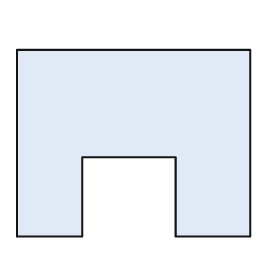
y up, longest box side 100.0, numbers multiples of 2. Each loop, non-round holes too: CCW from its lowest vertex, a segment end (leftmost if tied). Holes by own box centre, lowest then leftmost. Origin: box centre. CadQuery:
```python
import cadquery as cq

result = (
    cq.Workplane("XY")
    .moveTo(-50.0, -40.0)
    .lineTo(-22.0, -40.0)
    .lineTo(-22.0, -6.0)
    .lineTo(18.0, -6.0)
    .lineTo(18.0, -40.0)
    .lineTo(50.0, -40.0)
    .lineTo(50.0, 40.0)
    .lineTo(-50.0, 40.0)
    .close()
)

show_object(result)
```